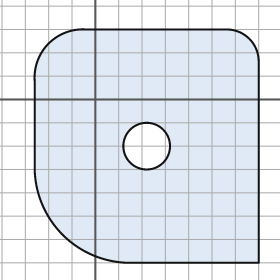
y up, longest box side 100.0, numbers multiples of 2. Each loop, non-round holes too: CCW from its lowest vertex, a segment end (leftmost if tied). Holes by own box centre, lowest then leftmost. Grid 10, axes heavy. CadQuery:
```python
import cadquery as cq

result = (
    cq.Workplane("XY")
    .moveTo(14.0, -70.0)
    .lineTo(70.0, -70.0)
    .lineTo(70.0, 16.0)
    .threePointArc((66.0, 26.0), (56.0, 30.0))
    .lineTo(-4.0, 30.0)
    .threePointArc((-20.0, 24.0), (-26.0, 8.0))
    .lineTo(-26.0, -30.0)
    .threePointArc((-14.0, -58.0), (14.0, -70.0))
    .close()
    .moveTo(22.0, -20.0)
    .circle(10.0)
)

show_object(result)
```